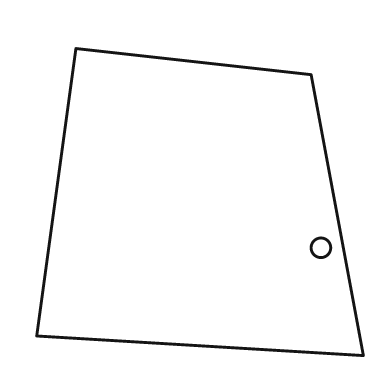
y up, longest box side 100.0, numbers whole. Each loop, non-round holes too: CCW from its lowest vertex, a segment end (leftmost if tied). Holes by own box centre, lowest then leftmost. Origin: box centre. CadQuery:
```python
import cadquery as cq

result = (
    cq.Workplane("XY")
    .moveTo(50.0, -47.0)
    .lineTo(34.0, 39.0)
    .lineTo(-38.0, 47.0)
    .lineTo(-50.0, -41.0)
    .close()
    .moveTo(37.0, -14.0)
    .circle(3.0)
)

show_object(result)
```